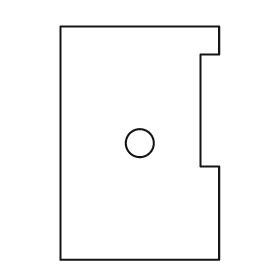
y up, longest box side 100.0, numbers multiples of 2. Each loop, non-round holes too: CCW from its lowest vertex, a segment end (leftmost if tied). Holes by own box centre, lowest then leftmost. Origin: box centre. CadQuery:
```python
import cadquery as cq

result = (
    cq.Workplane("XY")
    .moveTo(-34.0, -50.0)
    .lineTo(34.0, -50.0)
    .lineTo(34.0, -10.0)
    .lineTo(26.0, -10.0)
    .lineTo(26.0, 38.0)
    .lineTo(34.0, 38.0)
    .lineTo(34.0, 50.0)
    .lineTo(-34.0, 50.0)
    .close()
    .moveTo(0.0, 0.0)
    .circle(6.0)
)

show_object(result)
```